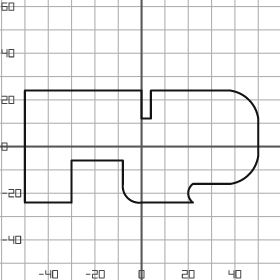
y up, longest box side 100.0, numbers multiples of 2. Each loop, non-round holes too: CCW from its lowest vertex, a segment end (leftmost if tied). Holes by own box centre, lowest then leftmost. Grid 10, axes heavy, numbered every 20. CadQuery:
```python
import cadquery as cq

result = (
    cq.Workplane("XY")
    .moveTo(-50.0, -24.0)
    .lineTo(-30.0, -24.0)
    .lineTo(-30.0, -6.0)
    .lineTo(-8.0, -6.0)
    .lineTo(-8.0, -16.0)
    .threePointArc((-6.0, -22.0), (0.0, -24.0))
    .lineTo(22.0, -24.0)
    .threePointArc((20.0, -20.0), (22.0, -16.0))
    .lineTo(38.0, -16.0)
    .threePointArc((46.0, -12.0), (50.0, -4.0))
    .lineTo(50.0, 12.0)
    .threePointArc((46.0, 20.0), (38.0, 24.0))
    .lineTo(4.0, 24.0)
    .lineTo(4.0, 12.0)
    .lineTo(0.0, 12.0)
    .lineTo(0.0, 24.0)
    .lineTo(-50.0, 24.0)
    .close()
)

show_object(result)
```